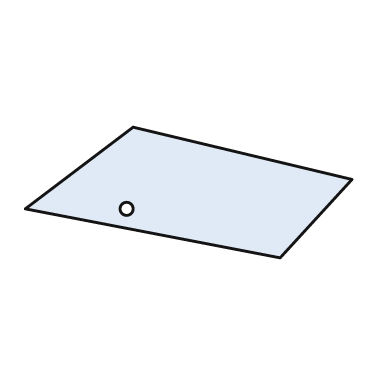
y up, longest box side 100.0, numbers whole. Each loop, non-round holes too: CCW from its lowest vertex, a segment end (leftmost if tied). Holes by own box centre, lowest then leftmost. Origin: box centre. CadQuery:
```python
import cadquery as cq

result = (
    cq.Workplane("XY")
    .moveTo(28.0, -20.0)
    .lineTo(50.0, 4.0)
    .lineTo(-17.0, 20.0)
    .lineTo(-50.0, -5.0)
    .close()
    .moveTo(-19.0, -5.0)
    .circle(2.0)
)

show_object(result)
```